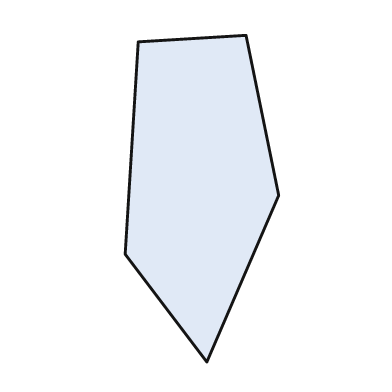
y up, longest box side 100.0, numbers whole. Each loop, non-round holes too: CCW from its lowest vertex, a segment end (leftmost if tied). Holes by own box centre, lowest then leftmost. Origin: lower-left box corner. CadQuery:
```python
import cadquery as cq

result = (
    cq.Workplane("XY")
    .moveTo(25.0, 0.0)
    .lineTo(47.0, 51.0)
    .lineTo(37.0, 100.0)
    .lineTo(4.0, 98.0)
    .lineTo(0.0, 33.0)
    .close()
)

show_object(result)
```